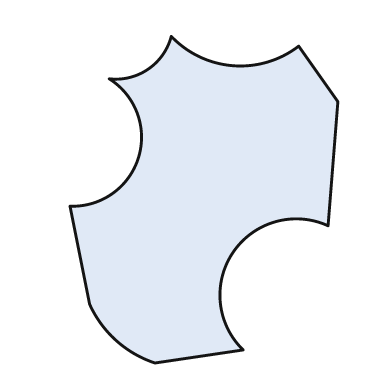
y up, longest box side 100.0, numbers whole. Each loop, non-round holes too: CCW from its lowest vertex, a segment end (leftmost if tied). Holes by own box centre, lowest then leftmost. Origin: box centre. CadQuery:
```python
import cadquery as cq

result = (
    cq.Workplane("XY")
    .moveTo(-15.0, -50.0)
    .lineTo(12.0, -46.0)
    .threePointArc((9.0, -16.0), (38.0, -8.0))
    .lineTo(41.0, 30.0)
    .lineTo(29.0, 47.0)
    .threePointArc((9.0, 41.0), (-10.0, 50.0))
    .threePointArc((-17.0, 40.0), (-29.0, 37.0))
    .threePointArc((-20.0, 13.0), (-41.0, -2.0))
    .lineTo(-35.0, -32.0)
    .threePointArc((-27.0, -43.0), (-15.0, -50.0))
    .close()
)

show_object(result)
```